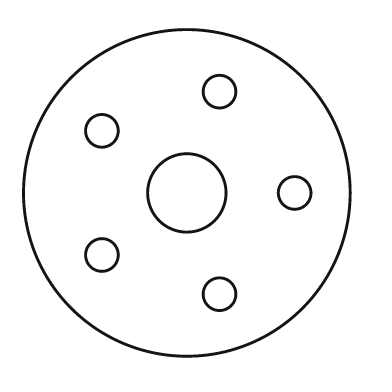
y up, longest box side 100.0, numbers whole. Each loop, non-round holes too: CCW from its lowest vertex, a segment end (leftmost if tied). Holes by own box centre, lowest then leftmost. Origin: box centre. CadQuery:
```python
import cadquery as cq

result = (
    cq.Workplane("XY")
    .moveTo(0.0, 0.0)
    .circle(50.0)
    .moveTo(10.0, -31.0)
    .circle(5.0)
    .moveTo(-26.0, -19.0)
    .circle(5.0)
    .moveTo(0.0, 0.0)
    .circle(12.0)
    .moveTo(33.0, 0.0)
    .circle(5.0)
    .moveTo(-26.0, 19.0)
    .circle(5.0)
    .moveTo(10.0, 31.0)
    .circle(5.0)
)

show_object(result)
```